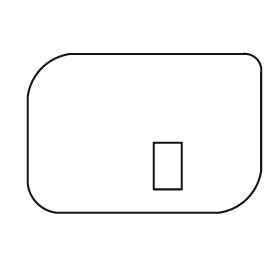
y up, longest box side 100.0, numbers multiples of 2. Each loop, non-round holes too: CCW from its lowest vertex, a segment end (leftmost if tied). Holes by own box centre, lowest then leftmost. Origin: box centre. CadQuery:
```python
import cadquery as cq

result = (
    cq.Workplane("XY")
    .moveTo(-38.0, -34.0)
    .lineTo(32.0, -34.0)
    .threePointArc((44.0, -28.0), (50.0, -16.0))
    .lineTo(50.0, 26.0)
    .threePointArc((48.0, 32.0), (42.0, 34.0))
    .lineTo(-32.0, 34.0)
    .threePointArc((-44.0, 28.0), (-50.0, 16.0))
    .lineTo(-50.0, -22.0)
    .threePointArc((-46.0, -30.0), (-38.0, -34.0))
    .close()
    .moveTo(4.0, -24.0)
    .lineTo(16.0, -24.0)
    .lineTo(16.0, -4.0)
    .lineTo(4.0, -4.0)
    .close()
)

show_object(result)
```